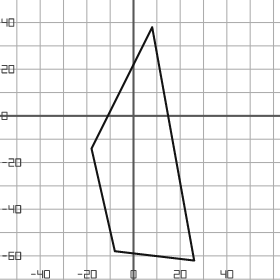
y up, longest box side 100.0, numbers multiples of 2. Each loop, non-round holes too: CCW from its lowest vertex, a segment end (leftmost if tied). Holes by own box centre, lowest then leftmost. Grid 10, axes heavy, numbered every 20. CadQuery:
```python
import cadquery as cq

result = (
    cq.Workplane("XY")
    .moveTo(26.0, -62.0)
    .lineTo(8.0, 38.0)
    .lineTo(-18.0, -14.0)
    .lineTo(-8.0, -58.0)
    .close()
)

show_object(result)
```